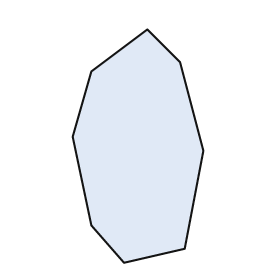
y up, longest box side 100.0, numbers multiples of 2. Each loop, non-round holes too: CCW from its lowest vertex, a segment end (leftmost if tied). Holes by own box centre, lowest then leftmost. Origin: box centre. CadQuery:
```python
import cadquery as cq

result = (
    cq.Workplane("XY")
    .moveTo(-6.0, -50.0)
    .lineTo(20.0, -44.0)
    .lineTo(28.0, -2.0)
    .lineTo(18.0, 36.0)
    .lineTo(4.0, 50.0)
    .lineTo(-20.0, 32.0)
    .lineTo(-28.0, 4.0)
    .lineTo(-20.0, -34.0)
    .close()
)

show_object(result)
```